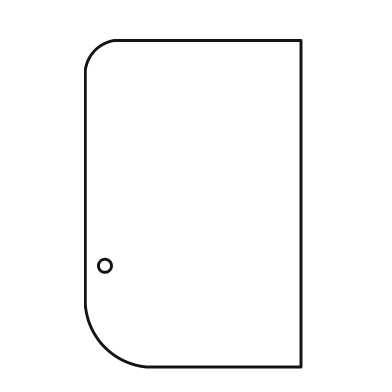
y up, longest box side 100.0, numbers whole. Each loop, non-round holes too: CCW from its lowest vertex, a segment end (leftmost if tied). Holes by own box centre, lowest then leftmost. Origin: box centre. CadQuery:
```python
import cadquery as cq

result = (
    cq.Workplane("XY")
    .moveTo(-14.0, -50.0)
    .lineTo(33.0, -50.0)
    .lineTo(33.0, 50.0)
    .lineTo(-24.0, 50.0)
    .threePointArc((-30.0, 47.0), (-33.0, 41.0))
    .lineTo(-33.0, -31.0)
    .threePointArc((-27.0, -44.0), (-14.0, -50.0))
    .close()
    .moveTo(-27.0, -19.0)
    .circle(2.0)
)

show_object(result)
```